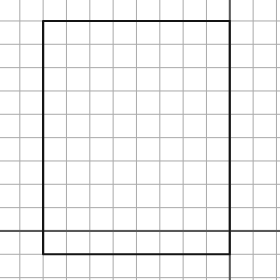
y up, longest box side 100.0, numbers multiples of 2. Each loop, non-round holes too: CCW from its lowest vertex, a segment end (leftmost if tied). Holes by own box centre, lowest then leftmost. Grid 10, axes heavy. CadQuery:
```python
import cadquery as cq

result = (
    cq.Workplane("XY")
    .moveTo(-80.0, -10.0)
    .lineTo(0.0, -10.0)
    .lineTo(0.0, 90.0)
    .lineTo(-80.0, 90.0)
    .close()
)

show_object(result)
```